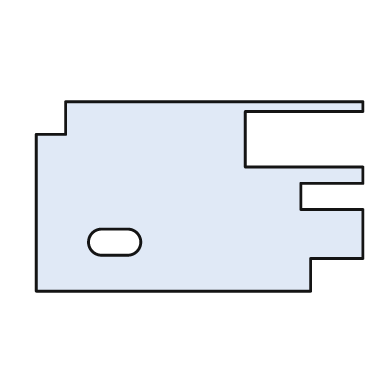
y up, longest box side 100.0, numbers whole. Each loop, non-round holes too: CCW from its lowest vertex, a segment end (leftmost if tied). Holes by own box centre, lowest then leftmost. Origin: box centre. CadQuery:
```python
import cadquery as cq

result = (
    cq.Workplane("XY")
    .moveTo(-50.0, -29.0)
    .lineTo(34.0, -29.0)
    .lineTo(34.0, -19.0)
    .lineTo(50.0, -19.0)
    .lineTo(50.0, -4.0)
    .lineTo(31.0, -4.0)
    .lineTo(31.0, 4.0)
    .lineTo(50.0, 4.0)
    .lineTo(50.0, 9.0)
    .lineTo(14.0, 9.0)
    .lineTo(14.0, 26.0)
    .lineTo(50.0, 26.0)
    .lineTo(50.0, 29.0)
    .lineTo(-41.0, 29.0)
    .lineTo(-41.0, 19.0)
    .lineTo(-50.0, 19.0)
    .close()
    .moveTo(-30.0, -18.0)
    .lineTo(-22.0, -18.0)
    .threePointArc((-18.0, -14.0), (-22.0, -10.0))
    .lineTo(-30.0, -10.0)
    .threePointArc((-34.0, -14.0), (-30.0, -18.0))
    .close()
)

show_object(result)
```